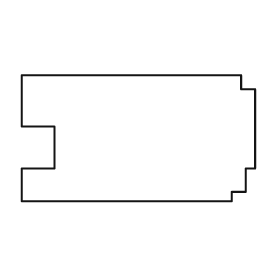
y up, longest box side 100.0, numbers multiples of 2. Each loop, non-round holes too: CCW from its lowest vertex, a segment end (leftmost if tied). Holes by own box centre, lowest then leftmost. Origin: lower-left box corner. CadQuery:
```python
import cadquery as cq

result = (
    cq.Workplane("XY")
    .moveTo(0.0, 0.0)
    .lineTo(90.0, 0.0)
    .lineTo(90.0, 4.0)
    .lineTo(96.0, 4.0)
    .lineTo(96.0, 14.0)
    .lineTo(100.0, 14.0)
    .lineTo(100.0, 48.0)
    .lineTo(94.0, 48.0)
    .lineTo(94.0, 54.0)
    .lineTo(0.0, 54.0)
    .lineTo(0.0, 32.0)
    .lineTo(14.0, 32.0)
    .lineTo(14.0, 14.0)
    .lineTo(0.0, 14.0)
    .close()
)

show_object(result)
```